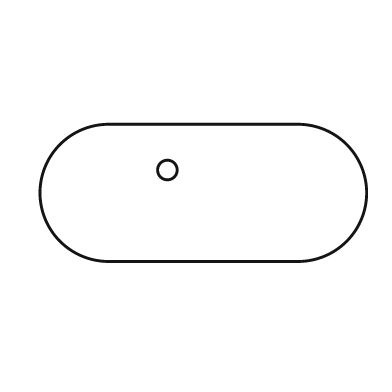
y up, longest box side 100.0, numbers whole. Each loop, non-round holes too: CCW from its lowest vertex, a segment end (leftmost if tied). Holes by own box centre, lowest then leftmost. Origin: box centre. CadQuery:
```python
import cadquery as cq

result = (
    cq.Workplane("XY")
    .moveTo(-29.0, -21.0)
    .lineTo(29.0, -21.0)
    .threePointArc((50.0, 0.0), (29.0, 21.0))
    .lineTo(-29.0, 21.0)
    .threePointArc((-50.0, 0.0), (-29.0, -21.0))
    .close()
    .moveTo(-11.0, 7.0)
    .circle(3.0)
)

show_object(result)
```